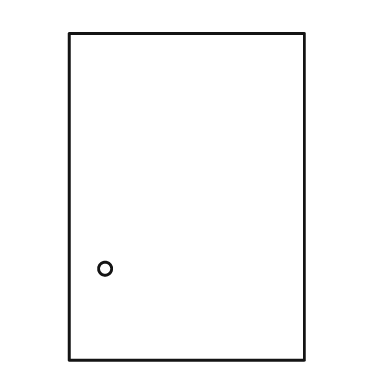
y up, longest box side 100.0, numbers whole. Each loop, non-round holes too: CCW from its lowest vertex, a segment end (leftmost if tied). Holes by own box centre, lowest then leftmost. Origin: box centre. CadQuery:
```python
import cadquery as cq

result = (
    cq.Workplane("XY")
    .moveTo(-36.0, -50.0)
    .lineTo(36.0, -50.0)
    .lineTo(36.0, 50.0)
    .lineTo(-36.0, 50.0)
    .close()
    .moveTo(-25.0, -22.0)
    .circle(2.0)
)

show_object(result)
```